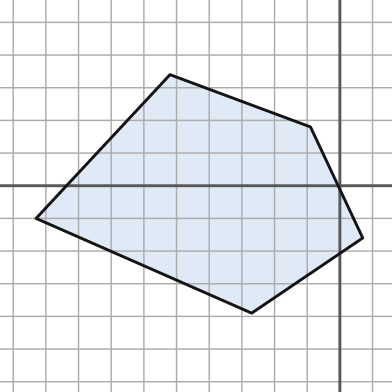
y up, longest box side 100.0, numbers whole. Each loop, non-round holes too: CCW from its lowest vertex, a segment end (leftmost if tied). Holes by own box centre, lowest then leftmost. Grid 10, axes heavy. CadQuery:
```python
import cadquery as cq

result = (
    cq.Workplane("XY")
    .moveTo(-27.0, -39.0)
    .lineTo(7.0, -16.0)
    .lineTo(-9.0, 18.0)
    .lineTo(-52.0, 34.0)
    .lineTo(-93.0, -10.0)
    .close()
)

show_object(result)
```